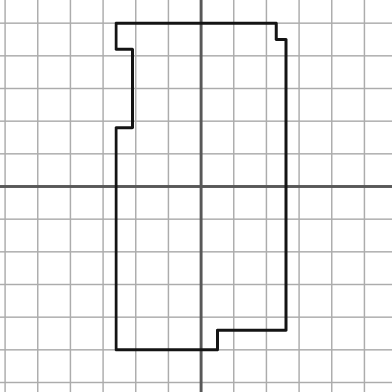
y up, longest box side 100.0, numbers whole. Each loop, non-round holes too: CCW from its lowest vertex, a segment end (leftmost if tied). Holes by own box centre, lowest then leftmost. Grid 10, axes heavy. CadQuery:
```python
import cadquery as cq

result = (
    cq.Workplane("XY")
    .moveTo(-26.0, -50.0)
    .lineTo(5.0, -50.0)
    .lineTo(5.0, -44.0)
    .lineTo(26.0, -44.0)
    .lineTo(26.0, 45.0)
    .lineTo(23.0, 45.0)
    .lineTo(23.0, 50.0)
    .lineTo(-26.0, 50.0)
    .lineTo(-26.0, 42.0)
    .lineTo(-21.0, 42.0)
    .lineTo(-21.0, 18.0)
    .lineTo(-26.0, 18.0)
    .close()
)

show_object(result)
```